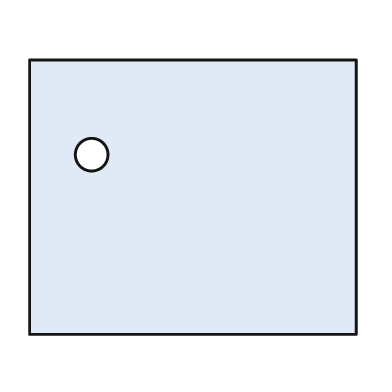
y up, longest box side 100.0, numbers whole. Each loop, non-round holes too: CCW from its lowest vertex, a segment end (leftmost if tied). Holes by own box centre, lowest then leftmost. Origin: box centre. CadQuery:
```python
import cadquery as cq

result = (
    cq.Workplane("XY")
    .moveTo(-50.0, -42.0)
    .lineTo(50.0, -42.0)
    .lineTo(50.0, 42.0)
    .lineTo(-50.0, 42.0)
    .close()
    .moveTo(-31.0, 13.0)
    .circle(5.0)
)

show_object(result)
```